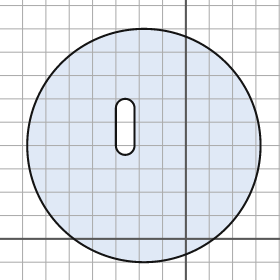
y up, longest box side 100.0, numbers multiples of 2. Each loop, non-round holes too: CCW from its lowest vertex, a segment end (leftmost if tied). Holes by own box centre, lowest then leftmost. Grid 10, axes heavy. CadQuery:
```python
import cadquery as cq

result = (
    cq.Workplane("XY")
    .moveTo(-18.0, 40.0)
    .circle(50.0)
    .moveTo(-30.0, 40.0)
    .threePointArc((-26.0, 36.0), (-22.0, 40.0))
    .lineTo(-22.0, 56.0)
    .threePointArc((-26.0, 60.0), (-30.0, 56.0))
    .close()
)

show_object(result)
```